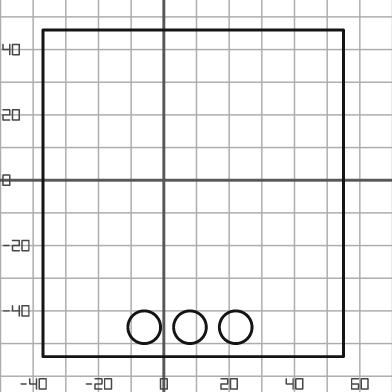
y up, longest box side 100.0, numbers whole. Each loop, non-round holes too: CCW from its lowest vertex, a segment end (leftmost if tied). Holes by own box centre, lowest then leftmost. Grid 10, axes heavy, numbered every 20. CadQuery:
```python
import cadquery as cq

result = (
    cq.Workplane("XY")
    .moveTo(-37.0, -54.0)
    .lineTo(55.0, -54.0)
    .lineTo(55.0, 46.0)
    .lineTo(-37.0, 46.0)
    .close()
    .moveTo(-6.0, -45.0)
    .circle(5.0)
    .moveTo(8.0, -45.0)
    .circle(5.0)
    .moveTo(22.0, -45.0)
    .circle(5.0)
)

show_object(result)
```